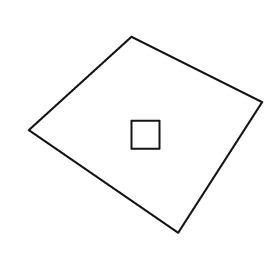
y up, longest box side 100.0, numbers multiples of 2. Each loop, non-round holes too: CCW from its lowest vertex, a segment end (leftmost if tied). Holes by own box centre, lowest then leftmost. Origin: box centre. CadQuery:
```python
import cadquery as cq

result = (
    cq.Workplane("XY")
    .moveTo(14.0, -42.0)
    .lineTo(50.0, 14.0)
    .lineTo(-6.0, 42.0)
    .lineTo(-50.0, 2.0)
    .close()
    .moveTo(-6.0, -6.0)
    .lineTo(6.0, -6.0)
    .lineTo(6.0, 6.0)
    .lineTo(-6.0, 6.0)
    .close()
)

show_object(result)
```